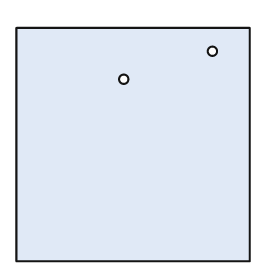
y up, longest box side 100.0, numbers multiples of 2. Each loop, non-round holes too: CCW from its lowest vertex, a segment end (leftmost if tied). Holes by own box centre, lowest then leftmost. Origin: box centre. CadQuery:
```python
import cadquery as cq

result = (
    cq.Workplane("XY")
    .moveTo(-50.0, -50.0)
    .lineTo(50.0, -50.0)
    .lineTo(50.0, 50.0)
    .lineTo(-50.0, 50.0)
    .close()
    .moveTo(-4.0, 28.0)
    .circle(2.0)
    .moveTo(34.0, 40.0)
    .circle(2.0)
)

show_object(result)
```